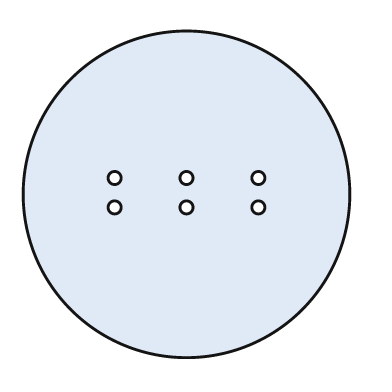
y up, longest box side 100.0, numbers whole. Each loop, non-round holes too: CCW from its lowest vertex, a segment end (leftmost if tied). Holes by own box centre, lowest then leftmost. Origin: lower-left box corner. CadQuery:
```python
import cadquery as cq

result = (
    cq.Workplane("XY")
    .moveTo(50.0, 50.0)
    .circle(50.0)
    .moveTo(28.0, 46.0)
    .circle(2.0)
    .moveTo(50.0, 46.0)
    .circle(2.0)
    .moveTo(72.0, 46.0)
    .circle(2.0)
    .moveTo(28.0, 55.0)
    .circle(2.0)
    .moveTo(50.0, 55.0)
    .circle(2.0)
    .moveTo(72.0, 55.0)
    .circle(2.0)
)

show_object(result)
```